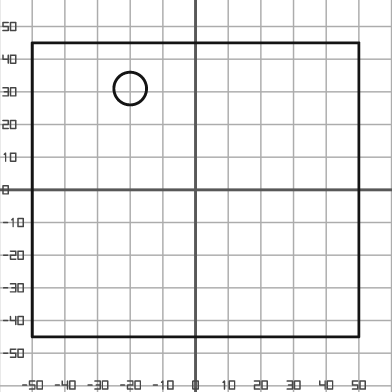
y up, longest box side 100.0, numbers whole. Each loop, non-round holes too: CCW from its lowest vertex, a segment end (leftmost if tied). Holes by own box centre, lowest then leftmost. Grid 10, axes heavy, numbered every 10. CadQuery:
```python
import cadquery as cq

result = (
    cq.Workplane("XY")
    .moveTo(-50.0, -45.0)
    .lineTo(50.0, -45.0)
    .lineTo(50.0, 45.0)
    .lineTo(-50.0, 45.0)
    .close()
    .moveTo(-20.0, 31.0)
    .circle(5.0)
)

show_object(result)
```